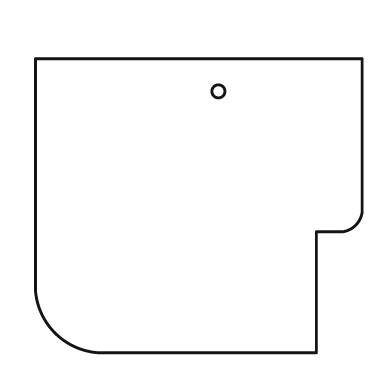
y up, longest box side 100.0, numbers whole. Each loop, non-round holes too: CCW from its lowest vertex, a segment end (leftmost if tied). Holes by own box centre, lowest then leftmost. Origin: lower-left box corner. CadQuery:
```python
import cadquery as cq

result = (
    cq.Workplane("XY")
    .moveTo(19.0, 0.0)
    .lineTo(86.0, 0.0)
    .lineTo(86.0, 37.0)
    .lineTo(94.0, 37.0)
    .threePointArc((98.0, 39.0), (100.0, 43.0))
    .lineTo(100.0, 90.0)
    .lineTo(0.0, 90.0)
    .lineTo(0.0, 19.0)
    .threePointArc((6.0, 6.0), (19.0, 0.0))
    .close()
    .moveTo(56.0, 80.0)
    .circle(2.0)
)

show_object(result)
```